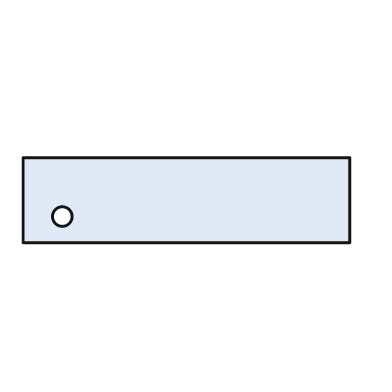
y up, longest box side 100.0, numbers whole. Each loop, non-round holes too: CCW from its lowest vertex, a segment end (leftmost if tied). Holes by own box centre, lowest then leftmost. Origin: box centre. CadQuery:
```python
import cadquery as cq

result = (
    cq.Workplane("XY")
    .moveTo(-50.0, -13.0)
    .lineTo(50.0, -13.0)
    .lineTo(50.0, 13.0)
    .lineTo(-50.0, 13.0)
    .close()
    .moveTo(-38.0, -5.0)
    .circle(3.0)
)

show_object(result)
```